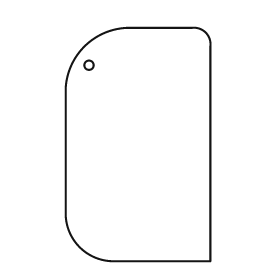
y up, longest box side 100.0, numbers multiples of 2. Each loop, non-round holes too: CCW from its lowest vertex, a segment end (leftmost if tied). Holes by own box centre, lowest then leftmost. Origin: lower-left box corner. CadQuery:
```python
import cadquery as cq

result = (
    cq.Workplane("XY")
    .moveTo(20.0, 0.0)
    .lineTo(62.0, 0.0)
    .lineTo(62.0, 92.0)
    .threePointArc((60.0, 98.0), (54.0, 100.0))
    .lineTo(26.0, 100.0)
    .threePointArc((8.0, 92.0), (0.0, 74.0))
    .lineTo(0.0, 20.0)
    .threePointArc((6.0, 6.0), (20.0, 0.0))
    .close()
    .moveTo(10.0, 84.0)
    .circle(2.0)
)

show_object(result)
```